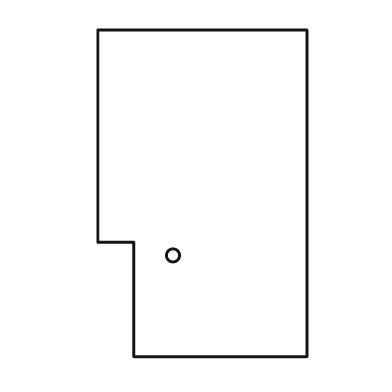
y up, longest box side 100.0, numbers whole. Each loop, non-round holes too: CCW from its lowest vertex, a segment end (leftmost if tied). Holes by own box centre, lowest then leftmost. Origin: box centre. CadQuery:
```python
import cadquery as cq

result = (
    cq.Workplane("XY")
    .moveTo(-21.0, -50.0)
    .lineTo(32.0, -50.0)
    .lineTo(32.0, 50.0)
    .lineTo(-32.0, 50.0)
    .lineTo(-32.0, -15.0)
    .lineTo(-21.0, -15.0)
    .close()
    .moveTo(-9.0, -19.0)
    .circle(2.0)
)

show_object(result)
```